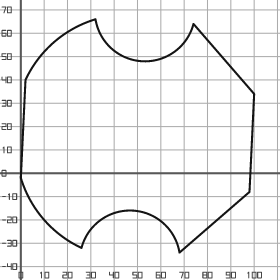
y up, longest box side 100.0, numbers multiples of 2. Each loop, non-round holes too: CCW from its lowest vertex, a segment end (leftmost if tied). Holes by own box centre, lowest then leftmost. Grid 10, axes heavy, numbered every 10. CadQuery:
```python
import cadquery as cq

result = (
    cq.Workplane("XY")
    .moveTo(68.0, -34.0)
    .lineTo(98.0, -8.0)
    .lineTo(100.0, 34.0)
    .lineTo(74.0, 64.0)
    .threePointArc((52.0, 48.0), (32.0, 66.0))
    .threePointArc((14.0, 56.0), (2.0, 40.0))
    .lineTo(0.0, -2.0)
    .threePointArc((10.0, -20.0), (26.0, -32.0))
    .threePointArc((48.0, -16.0), (68.0, -34.0))
    .close()
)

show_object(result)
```